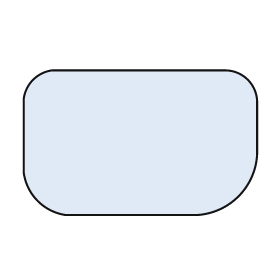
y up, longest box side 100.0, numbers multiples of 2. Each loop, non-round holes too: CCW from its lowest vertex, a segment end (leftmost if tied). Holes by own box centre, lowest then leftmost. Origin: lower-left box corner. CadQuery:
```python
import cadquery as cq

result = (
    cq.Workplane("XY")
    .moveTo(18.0, 0.0)
    .lineTo(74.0, 0.0)
    .threePointArc((92.0, 8.0), (100.0, 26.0))
    .lineTo(100.0, 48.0)
    .threePointArc((96.0, 58.0), (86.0, 62.0))
    .lineTo(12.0, 62.0)
    .threePointArc((4.0, 58.0), (0.0, 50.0))
    .lineTo(0.0, 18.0)
    .threePointArc((6.0, 6.0), (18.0, 0.0))
    .close()
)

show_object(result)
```